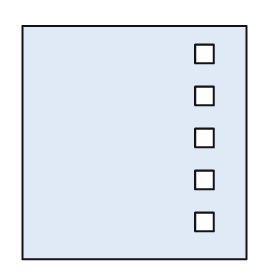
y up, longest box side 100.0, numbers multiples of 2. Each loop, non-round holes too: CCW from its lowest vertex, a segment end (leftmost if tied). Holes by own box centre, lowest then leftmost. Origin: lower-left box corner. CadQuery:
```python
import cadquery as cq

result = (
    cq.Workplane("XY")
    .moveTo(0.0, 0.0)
    .lineTo(96.0, 0.0)
    .lineTo(96.0, 100.0)
    .lineTo(0.0, 100.0)
    .close()
    .moveTo(74.0, 12.0)
    .lineTo(82.0, 12.0)
    .lineTo(82.0, 20.0)
    .lineTo(74.0, 20.0)
    .close()
    .moveTo(74.0, 30.0)
    .lineTo(82.0, 30.0)
    .lineTo(82.0, 38.0)
    .lineTo(74.0, 38.0)
    .close()
    .moveTo(74.0, 48.0)
    .lineTo(82.0, 48.0)
    .lineTo(82.0, 56.0)
    .lineTo(74.0, 56.0)
    .close()
    .moveTo(74.0, 66.0)
    .lineTo(82.0, 66.0)
    .lineTo(82.0, 74.0)
    .lineTo(74.0, 74.0)
    .close()
    .moveTo(74.0, 84.0)
    .lineTo(82.0, 84.0)
    .lineTo(82.0, 92.0)
    .lineTo(74.0, 92.0)
    .close()
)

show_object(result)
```